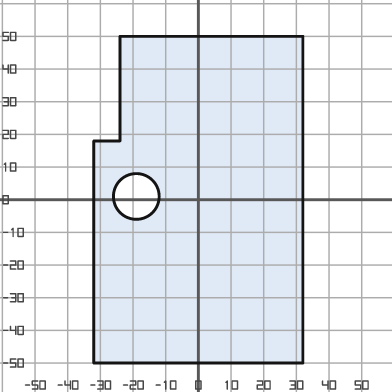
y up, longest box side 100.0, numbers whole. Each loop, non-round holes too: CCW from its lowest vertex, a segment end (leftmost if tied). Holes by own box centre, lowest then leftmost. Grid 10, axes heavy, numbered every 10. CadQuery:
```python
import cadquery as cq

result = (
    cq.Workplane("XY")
    .moveTo(-32.0, -50.0)
    .lineTo(32.0, -50.0)
    .lineTo(32.0, 50.0)
    .lineTo(-24.0, 50.0)
    .lineTo(-24.0, 18.0)
    .lineTo(-32.0, 18.0)
    .close()
    .moveTo(-19.0, 1.0)
    .circle(7.0)
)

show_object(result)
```